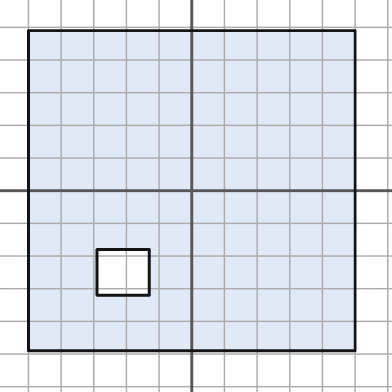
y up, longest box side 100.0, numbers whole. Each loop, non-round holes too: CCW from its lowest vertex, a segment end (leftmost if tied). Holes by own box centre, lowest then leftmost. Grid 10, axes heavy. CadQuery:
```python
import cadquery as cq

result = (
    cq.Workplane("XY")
    .moveTo(-50.0, -49.0)
    .lineTo(50.0, -49.0)
    .lineTo(50.0, 49.0)
    .lineTo(-50.0, 49.0)
    .close()
    .moveTo(-29.0, -32.0)
    .lineTo(-13.0, -32.0)
    .lineTo(-13.0, -18.0)
    .lineTo(-29.0, -18.0)
    .close()
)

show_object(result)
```